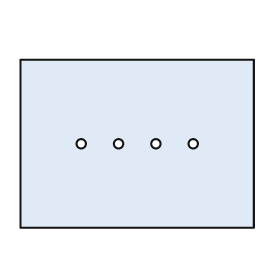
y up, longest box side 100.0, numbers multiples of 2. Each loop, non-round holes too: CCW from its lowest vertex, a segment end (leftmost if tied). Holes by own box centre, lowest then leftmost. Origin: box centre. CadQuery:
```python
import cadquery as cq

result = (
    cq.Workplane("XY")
    .moveTo(-50.0, -36.0)
    .lineTo(50.0, -36.0)
    .lineTo(50.0, 36.0)
    .lineTo(-50.0, 36.0)
    .close()
    .moveTo(-24.0, 0.0)
    .circle(2.0)
    .moveTo(-8.0, 0.0)
    .circle(2.0)
    .moveTo(8.0, 0.0)
    .circle(2.0)
    .moveTo(24.0, 0.0)
    .circle(2.0)
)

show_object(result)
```